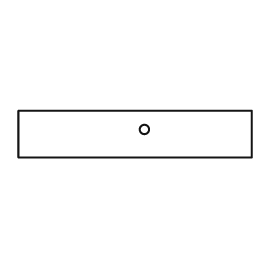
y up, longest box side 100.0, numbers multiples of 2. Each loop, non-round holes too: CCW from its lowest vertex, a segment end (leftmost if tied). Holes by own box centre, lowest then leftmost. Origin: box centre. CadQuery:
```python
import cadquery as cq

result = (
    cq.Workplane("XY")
    .moveTo(-50.0, -10.0)
    .lineTo(50.0, -10.0)
    .lineTo(50.0, 10.0)
    .lineTo(-50.0, 10.0)
    .close()
    .moveTo(4.0, 2.0)
    .circle(2.0)
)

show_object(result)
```